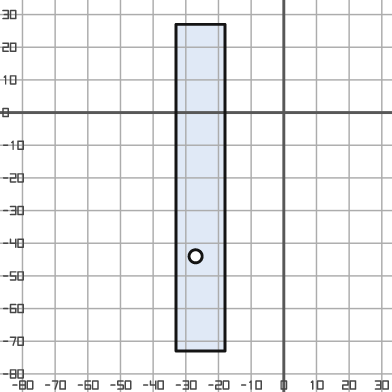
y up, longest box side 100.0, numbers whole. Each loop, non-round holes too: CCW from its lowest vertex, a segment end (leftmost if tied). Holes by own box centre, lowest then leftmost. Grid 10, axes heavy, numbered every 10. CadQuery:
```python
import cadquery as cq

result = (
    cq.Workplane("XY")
    .moveTo(-33.0, -73.0)
    .lineTo(-18.0, -73.0)
    .lineTo(-18.0, 27.0)
    .lineTo(-33.0, 27.0)
    .close()
    .moveTo(-27.0, -44.0)
    .circle(2.0)
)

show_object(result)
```